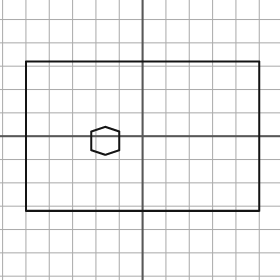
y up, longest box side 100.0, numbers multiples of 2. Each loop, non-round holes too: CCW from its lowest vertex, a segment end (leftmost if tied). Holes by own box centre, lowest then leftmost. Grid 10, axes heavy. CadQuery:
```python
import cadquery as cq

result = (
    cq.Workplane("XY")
    .moveTo(-50.0, -32.0)
    .lineTo(50.0, -32.0)
    .lineTo(50.0, 32.0)
    .lineTo(-50.0, 32.0)
    .close()
    .moveTo(-16.0, -8.0)
    .lineTo(-10.0, -6.0)
    .lineTo(-10.0, 2.0)
    .lineTo(-16.0, 4.0)
    .lineTo(-22.0, 2.0)
    .lineTo(-22.0, -6.0)
    .close()
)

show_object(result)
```